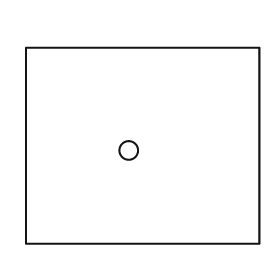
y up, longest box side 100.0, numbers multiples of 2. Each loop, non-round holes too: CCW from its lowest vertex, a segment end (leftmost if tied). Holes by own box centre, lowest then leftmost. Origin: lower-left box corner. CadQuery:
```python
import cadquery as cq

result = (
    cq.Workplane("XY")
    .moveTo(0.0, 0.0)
    .lineTo(100.0, 0.0)
    .lineTo(100.0, 84.0)
    .lineTo(0.0, 84.0)
    .close()
    .moveTo(44.0, 40.0)
    .circle(4.0)
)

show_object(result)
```